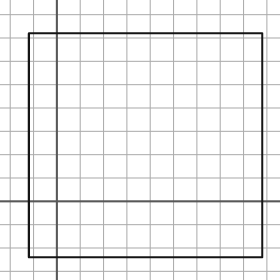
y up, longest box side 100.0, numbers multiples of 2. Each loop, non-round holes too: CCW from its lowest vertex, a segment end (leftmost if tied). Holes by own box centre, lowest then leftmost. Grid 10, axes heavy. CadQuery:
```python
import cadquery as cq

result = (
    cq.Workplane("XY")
    .moveTo(-12.0, -24.0)
    .lineTo(88.0, -24.0)
    .lineTo(88.0, 72.0)
    .lineTo(-12.0, 72.0)
    .close()
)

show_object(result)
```